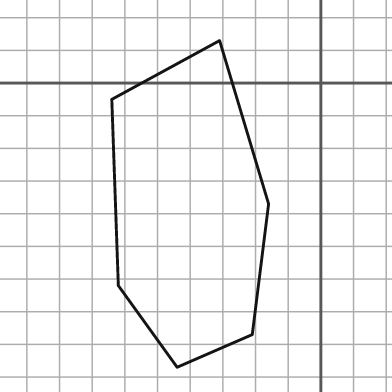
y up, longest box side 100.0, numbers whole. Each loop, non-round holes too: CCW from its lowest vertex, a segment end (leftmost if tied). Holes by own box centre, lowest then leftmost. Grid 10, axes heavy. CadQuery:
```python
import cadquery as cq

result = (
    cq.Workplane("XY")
    .moveTo(-44.0, -87.0)
    .lineTo(-21.0, -77.0)
    .lineTo(-16.0, -37.0)
    .lineTo(-31.0, 13.0)
    .lineTo(-64.0, -5.0)
    .lineTo(-62.0, -62.0)
    .close()
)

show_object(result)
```